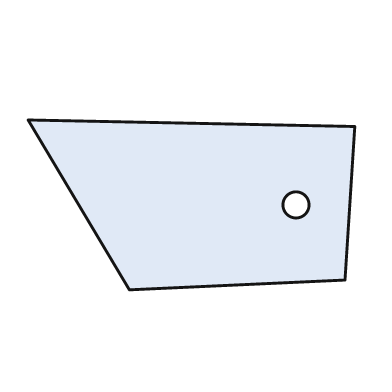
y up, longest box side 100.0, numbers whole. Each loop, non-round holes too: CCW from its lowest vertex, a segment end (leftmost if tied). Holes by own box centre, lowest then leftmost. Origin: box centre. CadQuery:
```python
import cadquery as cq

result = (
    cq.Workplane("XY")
    .moveTo(-19.0, -26.0)
    .lineTo(47.0, -23.0)
    .lineTo(50.0, 24.0)
    .lineTo(-50.0, 26.0)
    .close()
    .moveTo(32.0, 0.0)
    .circle(4.0)
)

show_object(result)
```